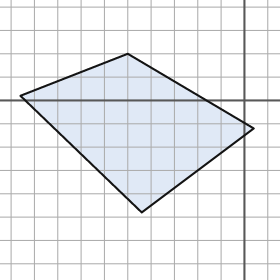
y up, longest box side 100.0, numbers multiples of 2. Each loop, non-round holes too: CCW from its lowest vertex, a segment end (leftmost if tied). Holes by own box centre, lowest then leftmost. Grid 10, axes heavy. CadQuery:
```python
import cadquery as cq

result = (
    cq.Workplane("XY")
    .moveTo(-44.0, -48.0)
    .lineTo(4.0, -12.0)
    .lineTo(-50.0, 20.0)
    .lineTo(-96.0, 2.0)
    .close()
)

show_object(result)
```